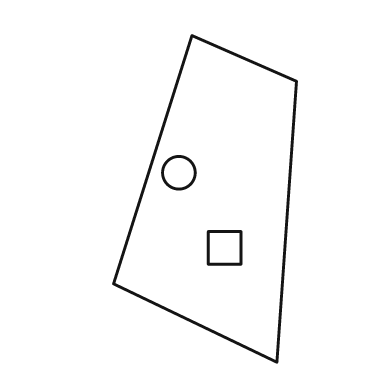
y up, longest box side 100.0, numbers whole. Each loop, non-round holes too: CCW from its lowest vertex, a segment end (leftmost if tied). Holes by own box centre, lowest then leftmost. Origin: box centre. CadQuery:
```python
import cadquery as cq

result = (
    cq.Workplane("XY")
    .moveTo(22.0, -50.0)
    .lineTo(28.0, 36.0)
    .lineTo(-4.0, 50.0)
    .lineTo(-28.0, -26.0)
    .close()
    .moveTo(1.0, -20.0)
    .lineTo(11.0, -20.0)
    .lineTo(11.0, -10.0)
    .lineTo(1.0, -10.0)
    .close()
    .moveTo(-8.0, 8.0)
    .circle(5.0)
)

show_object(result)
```